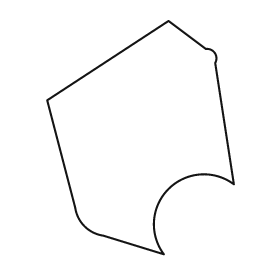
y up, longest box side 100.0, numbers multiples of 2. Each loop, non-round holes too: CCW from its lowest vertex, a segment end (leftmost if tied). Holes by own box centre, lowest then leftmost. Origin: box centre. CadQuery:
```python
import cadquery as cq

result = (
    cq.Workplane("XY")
    .moveTo(10.0, -50.0)
    .threePointArc((12.0, -22.0), (40.0, -20.0))
    .lineTo(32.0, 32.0)
    .threePointArc((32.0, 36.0), (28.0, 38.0))
    .lineTo(12.0, 50.0)
    .lineTo(-40.0, 16.0)
    .lineTo(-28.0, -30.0)
    .threePointArc((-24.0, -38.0), (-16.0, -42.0))
    .close()
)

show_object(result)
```